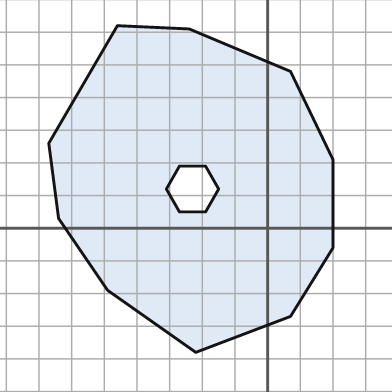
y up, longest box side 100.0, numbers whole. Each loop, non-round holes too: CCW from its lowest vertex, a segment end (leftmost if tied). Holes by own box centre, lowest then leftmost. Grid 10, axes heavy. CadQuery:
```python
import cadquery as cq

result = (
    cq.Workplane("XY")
    .moveTo(-22.0, -38.0)
    .lineTo(7.0, -27.0)
    .lineTo(20.0, -6.0)
    .lineTo(20.0, 21.0)
    .lineTo(7.0, 48.0)
    .lineTo(-24.0, 61.0)
    .lineTo(-46.0, 62.0)
    .lineTo(-67.0, 26.0)
    .lineTo(-64.0, 3.0)
    .lineTo(-49.0, -19.0)
    .close()
    .moveTo(-27.0, 5.0)
    .lineTo(-19.0, 5.0)
    .lineTo(-15.0, 12.0)
    .lineTo(-19.0, 19.0)
    .lineTo(-27.0, 19.0)
    .lineTo(-31.0, 12.0)
    .close()
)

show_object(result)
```